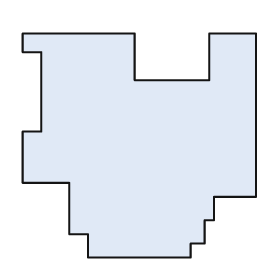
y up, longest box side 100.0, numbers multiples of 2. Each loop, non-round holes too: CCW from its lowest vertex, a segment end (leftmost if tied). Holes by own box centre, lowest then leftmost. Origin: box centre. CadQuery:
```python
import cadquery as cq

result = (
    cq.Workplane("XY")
    .moveTo(-22.0, -48.0)
    .lineTo(22.0, -48.0)
    .lineTo(22.0, -42.0)
    .lineTo(28.0, -42.0)
    .lineTo(28.0, -32.0)
    .lineTo(32.0, -32.0)
    .lineTo(32.0, -22.0)
    .lineTo(50.0, -22.0)
    .lineTo(50.0, 48.0)
    .lineTo(30.0, 48.0)
    .lineTo(30.0, 28.0)
    .lineTo(-2.0, 28.0)
    .lineTo(-2.0, 48.0)
    .lineTo(-50.0, 48.0)
    .lineTo(-50.0, 40.0)
    .lineTo(-42.0, 40.0)
    .lineTo(-42.0, 6.0)
    .lineTo(-50.0, 6.0)
    .lineTo(-50.0, -16.0)
    .lineTo(-30.0, -16.0)
    .lineTo(-30.0, -38.0)
    .lineTo(-22.0, -38.0)
    .close()
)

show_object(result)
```